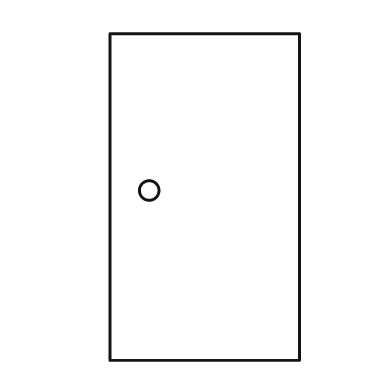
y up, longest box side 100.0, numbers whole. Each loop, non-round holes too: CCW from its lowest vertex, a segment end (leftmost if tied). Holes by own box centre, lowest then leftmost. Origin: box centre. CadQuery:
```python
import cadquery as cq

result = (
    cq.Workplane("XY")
    .moveTo(-29.0, -50.0)
    .lineTo(29.0, -50.0)
    .lineTo(29.0, 50.0)
    .lineTo(-29.0, 50.0)
    .close()
    .moveTo(-17.0, 2.0)
    .circle(3.0)
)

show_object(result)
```